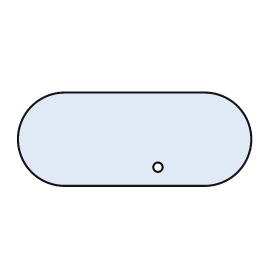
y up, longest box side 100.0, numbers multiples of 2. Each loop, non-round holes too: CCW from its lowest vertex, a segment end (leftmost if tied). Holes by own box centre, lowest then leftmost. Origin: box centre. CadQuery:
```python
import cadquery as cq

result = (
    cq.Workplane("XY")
    .moveTo(-30.0, -20.0)
    .lineTo(30.0, -20.0)
    .threePointArc((50.0, 0.0), (30.0, 20.0))
    .lineTo(-30.0, 20.0)
    .threePointArc((-50.0, 0.0), (-30.0, -20.0))
    .close()
    .moveTo(10.0, -12.0)
    .circle(2.0)
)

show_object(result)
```